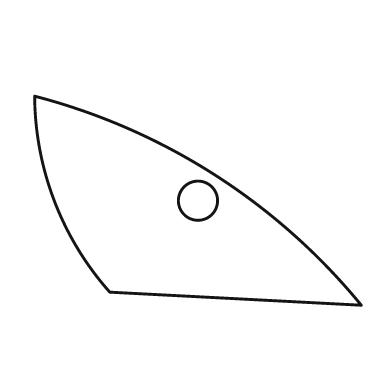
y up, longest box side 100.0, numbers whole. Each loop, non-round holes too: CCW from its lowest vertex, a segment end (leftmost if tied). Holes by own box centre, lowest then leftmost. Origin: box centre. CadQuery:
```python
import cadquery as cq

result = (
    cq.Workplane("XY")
    .moveTo(50.0, -32.0)
    .threePointArc((5.0, 8.0), (-50.0, 32.0))
    .threePointArc((-44.0, 0.0), (-27.0, -28.0))
    .close()
    .moveTo(0.0, 0.0)
    .circle(6.0)
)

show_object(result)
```